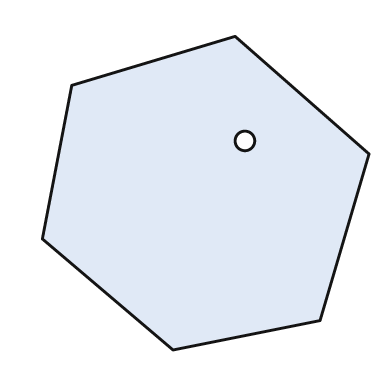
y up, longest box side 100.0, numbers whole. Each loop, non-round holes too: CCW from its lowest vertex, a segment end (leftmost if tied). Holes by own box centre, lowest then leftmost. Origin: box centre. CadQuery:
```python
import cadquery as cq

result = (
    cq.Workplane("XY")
    .moveTo(-10.0, -48.0)
    .lineTo(35.0, -39.0)
    .lineTo(50.0, 12.0)
    .lineTo(9.0, 48.0)
    .lineTo(-41.0, 33.0)
    .lineTo(-50.0, -14.0)
    .close()
    .moveTo(12.0, 16.0)
    .circle(3.0)
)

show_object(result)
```